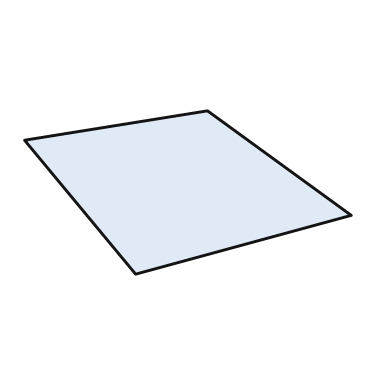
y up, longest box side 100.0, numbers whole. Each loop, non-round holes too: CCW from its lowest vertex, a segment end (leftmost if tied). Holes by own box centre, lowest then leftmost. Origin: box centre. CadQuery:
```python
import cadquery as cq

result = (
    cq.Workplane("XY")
    .moveTo(-16.0, -25.0)
    .lineTo(50.0, -7.0)
    .lineTo(6.0, 25.0)
    .lineTo(-50.0, 16.0)
    .close()
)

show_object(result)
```